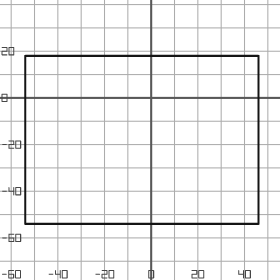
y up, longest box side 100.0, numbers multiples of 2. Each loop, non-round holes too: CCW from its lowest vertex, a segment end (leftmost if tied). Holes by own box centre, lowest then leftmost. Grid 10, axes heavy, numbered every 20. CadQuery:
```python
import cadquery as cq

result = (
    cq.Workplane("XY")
    .moveTo(-54.0, -54.0)
    .lineTo(46.0, -54.0)
    .lineTo(46.0, 18.0)
    .lineTo(-54.0, 18.0)
    .close()
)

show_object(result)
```